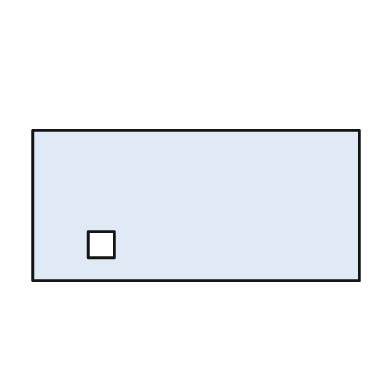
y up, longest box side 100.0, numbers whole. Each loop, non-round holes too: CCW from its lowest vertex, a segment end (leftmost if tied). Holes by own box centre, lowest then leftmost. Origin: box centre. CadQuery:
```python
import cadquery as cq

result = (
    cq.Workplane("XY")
    .moveTo(-50.0, -23.0)
    .lineTo(50.0, -23.0)
    .lineTo(50.0, 23.0)
    .lineTo(-50.0, 23.0)
    .close()
    .moveTo(-33.0, -16.0)
    .lineTo(-25.0, -16.0)
    .lineTo(-25.0, -8.0)
    .lineTo(-33.0, -8.0)
    .close()
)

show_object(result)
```